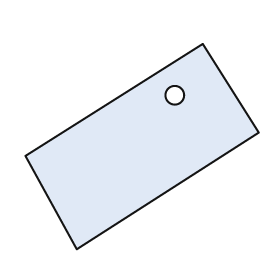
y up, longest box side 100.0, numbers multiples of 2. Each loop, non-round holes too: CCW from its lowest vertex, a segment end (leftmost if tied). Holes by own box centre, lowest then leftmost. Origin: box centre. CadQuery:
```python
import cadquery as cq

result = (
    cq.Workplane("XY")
    .moveTo(-28.0, -44.0)
    .lineTo(50.0, 6.0)
    .lineTo(26.0, 44.0)
    .lineTo(-50.0, -4.0)
    .close()
    .moveTo(14.0, 22.0)
    .circle(4.0)
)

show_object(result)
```